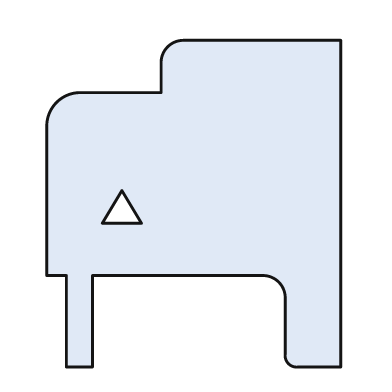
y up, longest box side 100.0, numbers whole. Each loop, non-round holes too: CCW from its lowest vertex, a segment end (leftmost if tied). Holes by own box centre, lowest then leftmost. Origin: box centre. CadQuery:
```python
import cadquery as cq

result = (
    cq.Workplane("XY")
    .moveTo(-39.0, -50.0)
    .lineTo(-31.0, -50.0)
    .lineTo(-31.0, -22.0)
    .lineTo(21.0, -22.0)
    .threePointArc((26.0, -24.0), (28.0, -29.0))
    .lineTo(28.0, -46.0)
    .threePointArc((29.0, -49.0), (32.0, -50.0))
    .lineTo(45.0, -50.0)
    .lineTo(45.0, 50.0)
    .lineTo(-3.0, 50.0)
    .threePointArc((-8.0, 48.0), (-10.0, 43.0))
    .lineTo(-10.0, 34.0)
    .lineTo(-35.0, 34.0)
    .threePointArc((-42.0, 31.0), (-45.0, 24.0))
    .lineTo(-45.0, -22.0)
    .lineTo(-39.0, -22.0)
    .close()
    .moveTo(-28.0, -6.0)
    .lineTo(-16.0, -6.0)
    .lineTo(-22.0, 4.0)
    .close()
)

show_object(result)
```